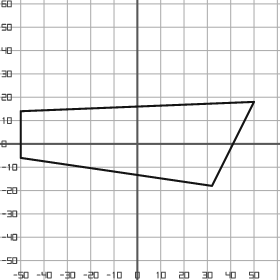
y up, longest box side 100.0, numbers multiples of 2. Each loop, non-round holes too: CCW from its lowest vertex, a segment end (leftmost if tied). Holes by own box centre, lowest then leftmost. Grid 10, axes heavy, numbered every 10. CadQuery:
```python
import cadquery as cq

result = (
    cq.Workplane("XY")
    .moveTo(32.0, -18.0)
    .lineTo(50.0, 18.0)
    .lineTo(-50.0, 14.0)
    .lineTo(-50.0, -6.0)
    .close()
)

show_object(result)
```